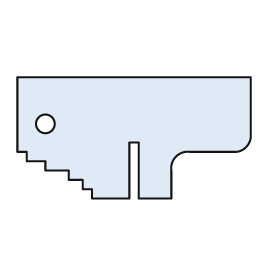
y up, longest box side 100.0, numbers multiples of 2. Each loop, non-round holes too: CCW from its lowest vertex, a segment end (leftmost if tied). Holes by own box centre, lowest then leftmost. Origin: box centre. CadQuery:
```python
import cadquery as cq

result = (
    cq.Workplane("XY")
    .moveTo(-18.0, -26.0)
    .lineTo(-2.0, -26.0)
    .lineTo(-2.0, -2.0)
    .lineTo(2.0, -2.0)
    .lineTo(2.0, -26.0)
    .lineTo(16.0, -26.0)
    .lineTo(16.0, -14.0)
    .threePointArc((18.0, -8.0), (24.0, -6.0))
    .lineTo(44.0, -6.0)
    .threePointArc((48.0, -4.0), (50.0, 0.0))
    .lineTo(50.0, 26.0)
    .lineTo(-50.0, 26.0)
    .lineTo(-50.0, -6.0)
    .lineTo(-46.0, -6.0)
    .lineTo(-46.0, -10.0)
    .lineTo(-38.0, -10.0)
    .lineTo(-38.0, -14.0)
    .lineTo(-28.0, -14.0)
    .lineTo(-28.0, -18.0)
    .lineTo(-22.0, -18.0)
    .lineTo(-22.0, -22.0)
    .lineTo(-18.0, -22.0)
    .close()
    .moveTo(-38.0, 6.0)
    .circle(4.0)
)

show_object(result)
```